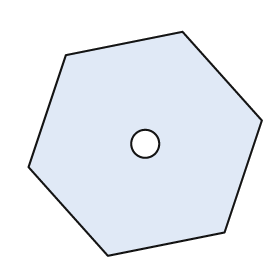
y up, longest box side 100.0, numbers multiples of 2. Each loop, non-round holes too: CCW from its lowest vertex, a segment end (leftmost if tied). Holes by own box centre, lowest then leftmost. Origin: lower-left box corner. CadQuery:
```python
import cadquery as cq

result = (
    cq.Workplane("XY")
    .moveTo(34.0, 0.0)
    .lineTo(84.0, 10.0)
    .lineTo(100.0, 58.0)
    .lineTo(66.0, 96.0)
    .lineTo(16.0, 86.0)
    .lineTo(0.0, 38.0)
    .close()
    .moveTo(50.0, 48.0)
    .circle(6.0)
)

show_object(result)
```